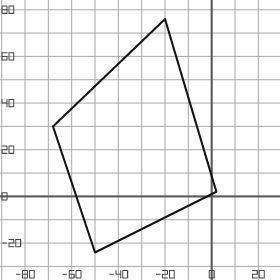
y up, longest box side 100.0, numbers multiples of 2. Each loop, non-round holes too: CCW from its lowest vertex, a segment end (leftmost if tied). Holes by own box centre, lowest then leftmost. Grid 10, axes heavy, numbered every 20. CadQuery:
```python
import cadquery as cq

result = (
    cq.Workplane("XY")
    .moveTo(-50.0, -24.0)
    .lineTo(2.0, 2.0)
    .lineTo(-20.0, 76.0)
    .lineTo(-68.0, 30.0)
    .close()
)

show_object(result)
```